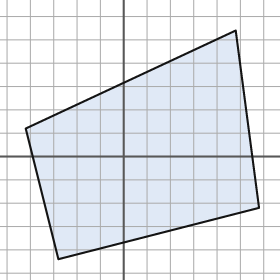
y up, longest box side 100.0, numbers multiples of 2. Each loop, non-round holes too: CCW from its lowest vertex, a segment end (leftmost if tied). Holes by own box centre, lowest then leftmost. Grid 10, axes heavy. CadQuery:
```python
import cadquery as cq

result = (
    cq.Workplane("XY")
    .moveTo(-28.0, -44.0)
    .lineTo(58.0, -22.0)
    .lineTo(48.0, 54.0)
    .lineTo(-42.0, 12.0)
    .close()
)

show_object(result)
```